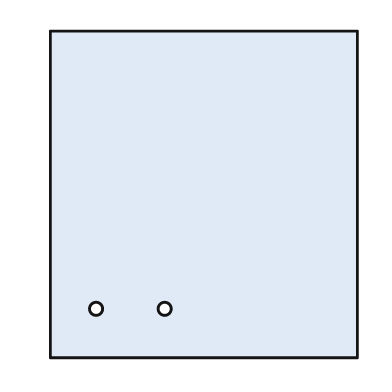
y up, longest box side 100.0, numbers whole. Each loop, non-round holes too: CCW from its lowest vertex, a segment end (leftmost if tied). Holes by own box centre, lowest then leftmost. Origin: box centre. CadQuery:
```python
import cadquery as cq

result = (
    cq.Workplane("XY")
    .moveTo(-47.0, -50.0)
    .lineTo(47.0, -50.0)
    .lineTo(47.0, 50.0)
    .lineTo(-47.0, 50.0)
    .close()
    .moveTo(-33.0, -35.0)
    .circle(2.0)
    .moveTo(-12.0, -35.0)
    .circle(2.0)
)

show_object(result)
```